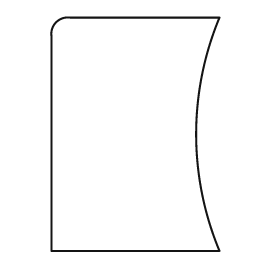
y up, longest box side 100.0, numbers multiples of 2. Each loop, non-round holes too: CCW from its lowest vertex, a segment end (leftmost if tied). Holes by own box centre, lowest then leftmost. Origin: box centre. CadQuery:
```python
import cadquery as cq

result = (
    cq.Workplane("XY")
    .moveTo(-36.0, -50.0)
    .lineTo(36.0, -50.0)
    .threePointArc((26.0, 0.0), (36.0, 50.0))
    .lineTo(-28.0, 50.0)
    .threePointArc((-34.0, 48.0), (-36.0, 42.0))
    .close()
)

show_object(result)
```